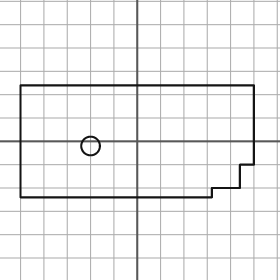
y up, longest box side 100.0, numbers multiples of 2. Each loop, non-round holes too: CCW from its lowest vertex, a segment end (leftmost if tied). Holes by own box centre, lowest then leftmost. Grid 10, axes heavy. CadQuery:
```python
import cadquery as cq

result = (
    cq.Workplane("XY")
    .moveTo(-50.0, -24.0)
    .lineTo(32.0, -24.0)
    .lineTo(32.0, -20.0)
    .lineTo(44.0, -20.0)
    .lineTo(44.0, -10.0)
    .lineTo(50.0, -10.0)
    .lineTo(50.0, 24.0)
    .lineTo(-50.0, 24.0)
    .close()
    .moveTo(-20.0, -2.0)
    .circle(4.0)
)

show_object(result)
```